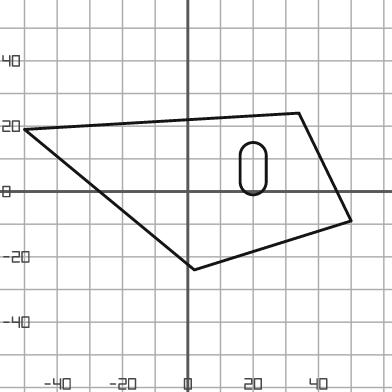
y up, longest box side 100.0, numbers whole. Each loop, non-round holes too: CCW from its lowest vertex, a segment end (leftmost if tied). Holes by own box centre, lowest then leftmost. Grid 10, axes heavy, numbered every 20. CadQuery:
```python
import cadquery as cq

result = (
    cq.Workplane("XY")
    .moveTo(2.0, -24.0)
    .lineTo(50.0, -9.0)
    .lineTo(34.0, 24.0)
    .lineTo(-50.0, 19.0)
    .close()
    .moveTo(16.0, 3.0)
    .threePointArc((20.0, -1.0), (24.0, 3.0))
    .lineTo(24.0, 11.0)
    .threePointArc((20.0, 15.0), (16.0, 11.0))
    .close()
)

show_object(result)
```